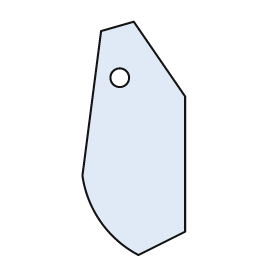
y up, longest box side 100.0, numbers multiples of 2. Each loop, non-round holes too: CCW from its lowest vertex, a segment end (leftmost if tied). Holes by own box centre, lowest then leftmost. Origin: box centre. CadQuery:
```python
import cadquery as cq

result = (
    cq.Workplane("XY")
    .moveTo(2.0, -50.0)
    .lineTo(22.0, -40.0)
    .lineTo(22.0, 18.0)
    .lineTo(0.0, 50.0)
    .lineTo(-14.0, 46.0)
    .lineTo(-22.0, -16.0)
    .threePointArc((-14.0, -36.0), (2.0, -50.0))
    .close()
    .moveTo(-6.0, 26.0)
    .circle(4.0)
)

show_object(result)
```